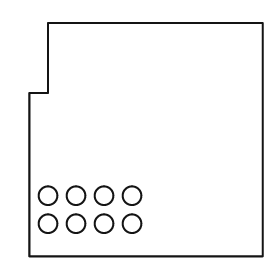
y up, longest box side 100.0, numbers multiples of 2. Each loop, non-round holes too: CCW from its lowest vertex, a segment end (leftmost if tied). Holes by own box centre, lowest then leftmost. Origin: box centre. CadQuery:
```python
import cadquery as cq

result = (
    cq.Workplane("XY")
    .moveTo(-50.0, -50.0)
    .lineTo(50.0, -50.0)
    .lineTo(50.0, 50.0)
    .lineTo(-42.0, 50.0)
    .lineTo(-42.0, 20.0)
    .lineTo(-50.0, 20.0)
    .close()
    .moveTo(-42.0, -36.0)
    .circle(4.0)
    .moveTo(-30.0, -36.0)
    .circle(4.0)
    .moveTo(-18.0, -36.0)
    .circle(4.0)
    .moveTo(-6.0, -36.0)
    .circle(4.0)
    .moveTo(-42.0, -24.0)
    .circle(4.0)
    .moveTo(-30.0, -24.0)
    .circle(4.0)
    .moveTo(-18.0, -24.0)
    .circle(4.0)
    .moveTo(-6.0, -24.0)
    .circle(4.0)
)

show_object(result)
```